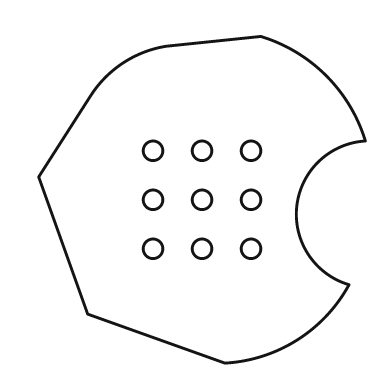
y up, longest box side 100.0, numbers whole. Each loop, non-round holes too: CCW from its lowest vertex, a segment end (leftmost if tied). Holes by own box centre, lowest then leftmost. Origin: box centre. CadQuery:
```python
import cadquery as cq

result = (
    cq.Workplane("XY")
    .moveTo(7.0, -50.0)
    .threePointArc((29.0, -43.0), (45.0, -26.0))
    .threePointArc((29.0, -2.0), (50.0, 18.0))
    .threePointArc((38.0, 38.0), (18.0, 50.0))
    .lineTo(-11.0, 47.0)
    .threePointArc((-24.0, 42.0), (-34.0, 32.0))
    .lineTo(-50.0, 7.0)
    .lineTo(-35.0, -35.0)
    .close()
    .moveTo(-15.0, -15.0)
    .circle(3.0)
    .moveTo(0.0, -15.0)
    .circle(3.0)
    .moveTo(15.0, -15.0)
    .circle(3.0)
    .moveTo(-15.0, 0.0)
    .circle(3.0)
    .moveTo(0.0, 0.0)
    .circle(3.0)
    .moveTo(15.0, 0.0)
    .circle(3.0)
    .moveTo(-15.0, 15.0)
    .circle(3.0)
    .moveTo(0.0, 15.0)
    .circle(3.0)
    .moveTo(15.0, 15.0)
    .circle(3.0)
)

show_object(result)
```